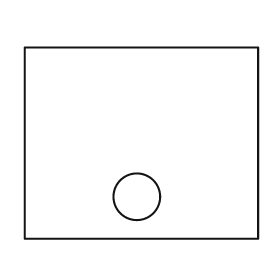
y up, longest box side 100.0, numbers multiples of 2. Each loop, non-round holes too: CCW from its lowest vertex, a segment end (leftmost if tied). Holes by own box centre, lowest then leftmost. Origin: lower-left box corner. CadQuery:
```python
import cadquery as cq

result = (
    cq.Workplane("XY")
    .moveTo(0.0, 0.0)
    .lineTo(100.0, 0.0)
    .lineTo(100.0, 82.0)
    .lineTo(0.0, 82.0)
    .close()
    .moveTo(48.0, 18.0)
    .circle(10.0)
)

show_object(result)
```